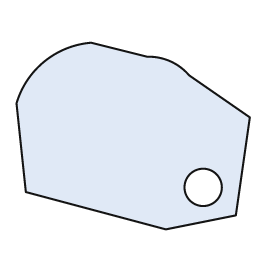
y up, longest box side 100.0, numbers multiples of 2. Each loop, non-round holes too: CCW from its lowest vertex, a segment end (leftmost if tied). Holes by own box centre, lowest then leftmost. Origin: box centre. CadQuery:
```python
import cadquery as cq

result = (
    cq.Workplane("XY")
    .moveTo(14.0, -40.0)
    .lineTo(44.0, -34.0)
    .lineTo(50.0, 8.0)
    .lineTo(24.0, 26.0)
    .threePointArc((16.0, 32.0), (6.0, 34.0))
    .lineTo(-18.0, 40.0)
    .threePointArc((-38.0, 32.0), (-50.0, 14.0))
    .lineTo(-46.0, -24.0)
    .close()
    .moveTo(30.0, -22.0)
    .circle(8.0)
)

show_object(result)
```